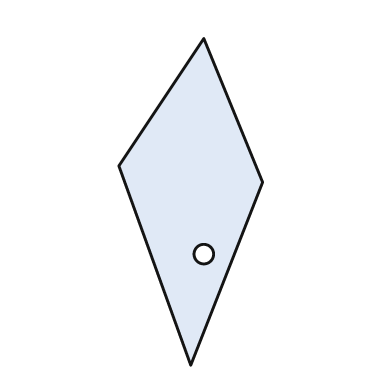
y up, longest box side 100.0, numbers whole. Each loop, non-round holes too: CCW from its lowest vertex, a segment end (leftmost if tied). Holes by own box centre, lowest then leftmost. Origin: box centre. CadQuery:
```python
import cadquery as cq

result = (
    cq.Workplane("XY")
    .moveTo(0.0, -50.0)
    .lineTo(22.0, 6.0)
    .lineTo(4.0, 50.0)
    .lineTo(-22.0, 11.0)
    .close()
    .moveTo(4.0, -16.0)
    .circle(3.0)
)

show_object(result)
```